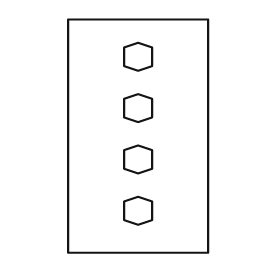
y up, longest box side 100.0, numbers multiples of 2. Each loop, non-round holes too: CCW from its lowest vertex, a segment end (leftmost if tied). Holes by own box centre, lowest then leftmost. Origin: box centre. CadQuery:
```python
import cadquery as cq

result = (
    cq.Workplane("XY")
    .moveTo(-30.0, -50.0)
    .lineTo(30.0, -50.0)
    .lineTo(30.0, 50.0)
    .lineTo(-30.0, 50.0)
    .close()
    .moveTo(0.0, -38.0)
    .lineTo(6.0, -36.0)
    .lineTo(6.0, -28.0)
    .lineTo(0.0, -26.0)
    .lineTo(-6.0, -28.0)
    .lineTo(-6.0, -36.0)
    .close()
    .moveTo(0.0, -16.0)
    .lineTo(6.0, -14.0)
    .lineTo(6.0, -6.0)
    .lineTo(0.0, -4.0)
    .lineTo(-6.0, -6.0)
    .lineTo(-6.0, -14.0)
    .close()
    .moveTo(0.0, 6.0)
    .lineTo(6.0, 8.0)
    .lineTo(6.0, 16.0)
    .lineTo(0.0, 18.0)
    .lineTo(-6.0, 16.0)
    .lineTo(-6.0, 8.0)
    .close()
    .moveTo(0.0, 28.0)
    .lineTo(6.0, 30.0)
    .lineTo(6.0, 38.0)
    .lineTo(0.0, 40.0)
    .lineTo(-6.0, 38.0)
    .lineTo(-6.0, 30.0)
    .close()
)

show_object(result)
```